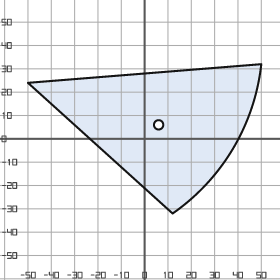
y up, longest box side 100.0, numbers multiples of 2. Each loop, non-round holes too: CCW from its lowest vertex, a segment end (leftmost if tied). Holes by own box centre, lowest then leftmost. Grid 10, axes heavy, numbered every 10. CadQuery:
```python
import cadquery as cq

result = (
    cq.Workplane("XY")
    .moveTo(12.0, -32.0)
    .threePointArc((38.0, -4.0), (50.0, 32.0))
    .lineTo(-50.0, 24.0)
    .close()
    .moveTo(6.0, 6.0)
    .circle(2.0)
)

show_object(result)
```